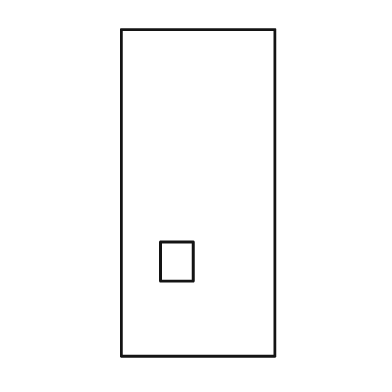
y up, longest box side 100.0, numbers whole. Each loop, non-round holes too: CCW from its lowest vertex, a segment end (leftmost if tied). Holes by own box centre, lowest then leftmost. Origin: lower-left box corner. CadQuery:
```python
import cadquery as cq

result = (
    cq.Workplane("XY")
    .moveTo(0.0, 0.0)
    .lineTo(47.0, 0.0)
    .lineTo(47.0, 100.0)
    .lineTo(0.0, 100.0)
    .close()
    .moveTo(12.0, 23.0)
    .lineTo(22.0, 23.0)
    .lineTo(22.0, 35.0)
    .lineTo(12.0, 35.0)
    .close()
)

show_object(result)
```